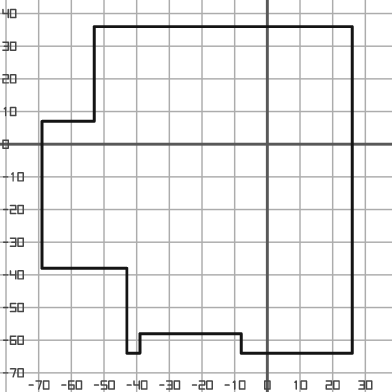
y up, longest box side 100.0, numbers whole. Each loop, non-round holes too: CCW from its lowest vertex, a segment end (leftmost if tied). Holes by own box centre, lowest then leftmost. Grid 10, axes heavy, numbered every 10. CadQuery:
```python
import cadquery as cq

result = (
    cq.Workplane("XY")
    .moveTo(-43.0, -64.0)
    .lineTo(-39.0, -64.0)
    .lineTo(-39.0, -58.0)
    .lineTo(-8.0, -58.0)
    .lineTo(-8.0, -64.0)
    .lineTo(26.0, -64.0)
    .lineTo(26.0, 36.0)
    .lineTo(-53.0, 36.0)
    .lineTo(-53.0, 7.0)
    .lineTo(-69.0, 7.0)
    .lineTo(-69.0, -38.0)
    .lineTo(-43.0, -38.0)
    .close()
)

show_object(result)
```